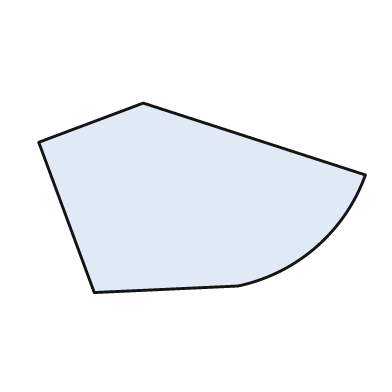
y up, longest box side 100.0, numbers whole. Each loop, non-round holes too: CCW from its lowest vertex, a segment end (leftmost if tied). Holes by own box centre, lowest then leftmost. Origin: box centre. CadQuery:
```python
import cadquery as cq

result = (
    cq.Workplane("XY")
    .moveTo(-33.0, -29.0)
    .lineTo(11.0, -27.0)
    .threePointArc((35.0, -15.0), (50.0, 7.0))
    .lineTo(-18.0, 29.0)
    .lineTo(-50.0, 17.0)
    .close()
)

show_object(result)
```